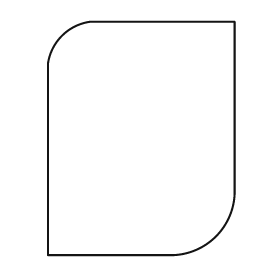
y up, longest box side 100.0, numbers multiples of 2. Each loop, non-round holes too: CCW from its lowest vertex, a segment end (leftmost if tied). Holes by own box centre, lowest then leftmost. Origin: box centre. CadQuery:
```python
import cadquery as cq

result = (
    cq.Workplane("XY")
    .moveTo(-40.0, -50.0)
    .lineTo(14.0, -50.0)
    .threePointArc((32.0, -42.0), (40.0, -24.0))
    .lineTo(40.0, 50.0)
    .lineTo(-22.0, 50.0)
    .threePointArc((-34.0, 44.0), (-40.0, 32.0))
    .close()
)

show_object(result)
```